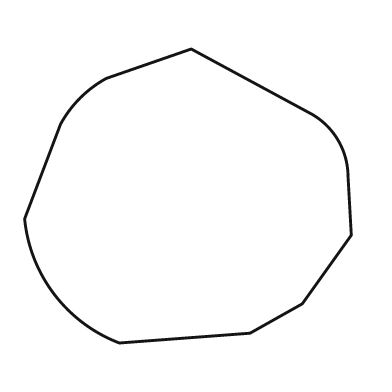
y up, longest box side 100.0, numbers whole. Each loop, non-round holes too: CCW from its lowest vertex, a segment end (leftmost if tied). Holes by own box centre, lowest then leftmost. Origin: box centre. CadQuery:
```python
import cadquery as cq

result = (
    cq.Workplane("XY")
    .moveTo(-21.0, -45.0)
    .lineTo(19.0, -42.0)
    .lineTo(35.0, -33.0)
    .lineTo(50.0, -12.0)
    .lineTo(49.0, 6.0)
    .threePointArc((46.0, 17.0), (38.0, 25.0))
    .lineTo(1.0, 45.0)
    .lineTo(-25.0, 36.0)
    .threePointArc((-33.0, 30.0), (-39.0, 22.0))
    .lineTo(-50.0, -7.0)
    .threePointArc((-41.0, -30.0), (-21.0, -45.0))
    .close()
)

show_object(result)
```